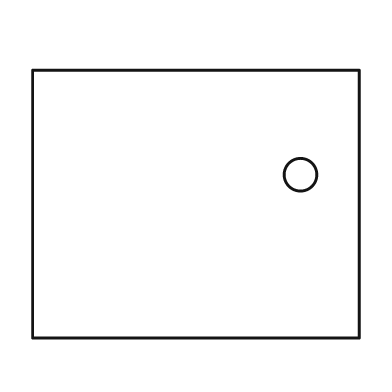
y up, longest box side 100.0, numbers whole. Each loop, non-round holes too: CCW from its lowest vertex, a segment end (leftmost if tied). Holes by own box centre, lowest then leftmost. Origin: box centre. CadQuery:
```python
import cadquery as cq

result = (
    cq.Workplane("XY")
    .moveTo(-50.0, -41.0)
    .lineTo(50.0, -41.0)
    .lineTo(50.0, 41.0)
    .lineTo(-50.0, 41.0)
    .close()
    .moveTo(32.0, 9.0)
    .circle(5.0)
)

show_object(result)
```